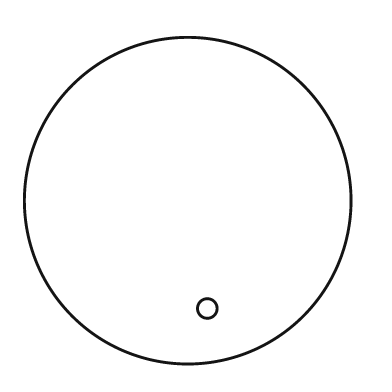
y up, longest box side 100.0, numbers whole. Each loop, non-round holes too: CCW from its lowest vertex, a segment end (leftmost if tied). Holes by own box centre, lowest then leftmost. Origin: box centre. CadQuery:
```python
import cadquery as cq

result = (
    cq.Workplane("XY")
    .moveTo(0.0, 0.0)
    .circle(50.0)
    .moveTo(6.0, -33.0)
    .circle(3.0)
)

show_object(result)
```